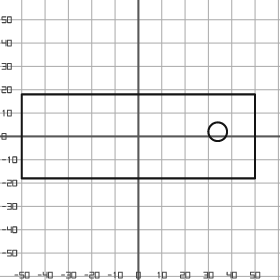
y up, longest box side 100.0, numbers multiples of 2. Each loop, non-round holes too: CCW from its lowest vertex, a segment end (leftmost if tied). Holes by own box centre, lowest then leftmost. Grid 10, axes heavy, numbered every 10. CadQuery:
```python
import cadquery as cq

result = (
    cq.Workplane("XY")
    .moveTo(-50.0, -18.0)
    .lineTo(50.0, -18.0)
    .lineTo(50.0, 18.0)
    .lineTo(-50.0, 18.0)
    .close()
    .moveTo(34.0, 2.0)
    .circle(4.0)
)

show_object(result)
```